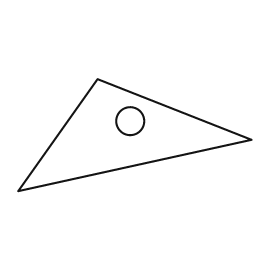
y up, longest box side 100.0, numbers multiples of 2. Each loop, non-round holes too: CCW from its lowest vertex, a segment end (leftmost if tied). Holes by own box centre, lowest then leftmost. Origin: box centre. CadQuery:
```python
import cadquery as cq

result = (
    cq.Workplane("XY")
    .moveTo(-50.0, -24.0)
    .lineTo(50.0, -2.0)
    .lineTo(-16.0, 24.0)
    .close()
    .moveTo(-2.0, 6.0)
    .circle(6.0)
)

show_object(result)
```